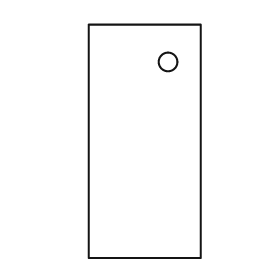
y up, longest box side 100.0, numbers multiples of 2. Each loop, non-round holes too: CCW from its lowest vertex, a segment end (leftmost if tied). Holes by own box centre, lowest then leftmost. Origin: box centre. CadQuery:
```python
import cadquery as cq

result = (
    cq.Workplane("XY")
    .moveTo(-24.0, -50.0)
    .lineTo(24.0, -50.0)
    .lineTo(24.0, 50.0)
    .lineTo(-24.0, 50.0)
    .close()
    .moveTo(10.0, 34.0)
    .circle(4.0)
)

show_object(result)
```